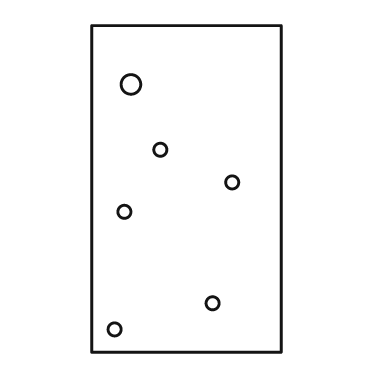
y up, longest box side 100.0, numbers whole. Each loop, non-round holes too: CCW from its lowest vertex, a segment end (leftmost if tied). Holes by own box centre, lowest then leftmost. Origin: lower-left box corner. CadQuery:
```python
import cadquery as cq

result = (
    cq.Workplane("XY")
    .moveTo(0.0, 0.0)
    .lineTo(58.0, 0.0)
    .lineTo(58.0, 100.0)
    .lineTo(0.0, 100.0)
    .close()
    .moveTo(7.0, 7.0)
    .circle(2.0)
    .moveTo(37.0, 15.0)
    .circle(2.0)
    .moveTo(10.0, 43.0)
    .circle(2.0)
    .moveTo(43.0, 52.0)
    .circle(2.0)
    .moveTo(21.0, 62.0)
    .circle(2.0)
    .moveTo(12.0, 82.0)
    .circle(3.0)
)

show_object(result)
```